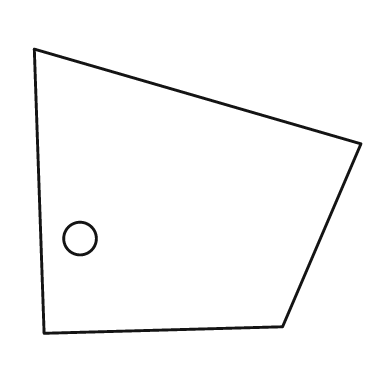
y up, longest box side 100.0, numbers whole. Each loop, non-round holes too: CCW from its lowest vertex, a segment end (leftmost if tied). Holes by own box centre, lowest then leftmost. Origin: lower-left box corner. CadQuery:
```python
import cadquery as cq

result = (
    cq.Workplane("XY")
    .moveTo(3.0, 0.0)
    .lineTo(76.0, 2.0)
    .lineTo(100.0, 58.0)
    .lineTo(0.0, 87.0)
    .close()
    .moveTo(14.0, 29.0)
    .circle(5.0)
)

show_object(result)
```